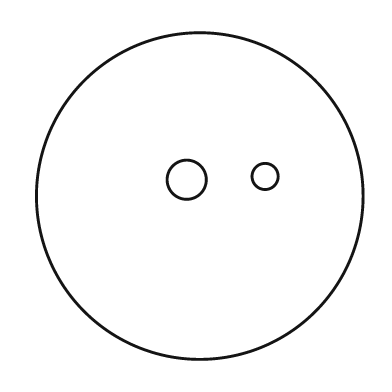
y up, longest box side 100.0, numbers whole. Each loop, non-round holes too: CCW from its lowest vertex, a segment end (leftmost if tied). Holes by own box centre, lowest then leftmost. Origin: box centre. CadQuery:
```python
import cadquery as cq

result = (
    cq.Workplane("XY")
    .moveTo(0.0, 0.0)
    .circle(50.0)
    .moveTo(-4.0, 5.0)
    .circle(6.0)
    .moveTo(20.0, 6.0)
    .circle(4.0)
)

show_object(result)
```